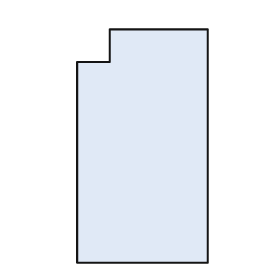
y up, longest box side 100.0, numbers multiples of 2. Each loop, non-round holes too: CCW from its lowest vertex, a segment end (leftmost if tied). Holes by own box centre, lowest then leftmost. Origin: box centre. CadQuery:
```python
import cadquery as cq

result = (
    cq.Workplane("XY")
    .moveTo(-28.0, -50.0)
    .lineTo(28.0, -50.0)
    .lineTo(28.0, 50.0)
    .lineTo(-14.0, 50.0)
    .lineTo(-14.0, 36.0)
    .lineTo(-28.0, 36.0)
    .close()
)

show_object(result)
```